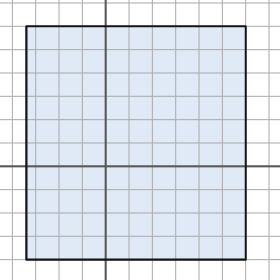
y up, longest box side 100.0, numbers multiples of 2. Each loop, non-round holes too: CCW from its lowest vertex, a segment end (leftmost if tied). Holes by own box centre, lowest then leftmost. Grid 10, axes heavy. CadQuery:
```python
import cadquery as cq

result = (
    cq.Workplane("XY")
    .moveTo(-34.0, -40.0)
    .lineTo(60.0, -40.0)
    .lineTo(60.0, 60.0)
    .lineTo(-34.0, 60.0)
    .close()
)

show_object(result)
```